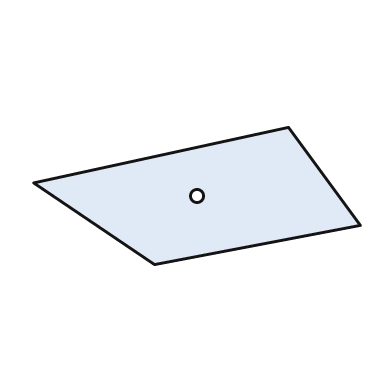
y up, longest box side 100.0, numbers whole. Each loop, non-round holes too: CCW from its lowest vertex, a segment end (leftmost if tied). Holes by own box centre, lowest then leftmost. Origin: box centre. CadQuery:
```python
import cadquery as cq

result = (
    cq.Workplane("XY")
    .moveTo(-13.0, -21.0)
    .lineTo(50.0, -9.0)
    .lineTo(28.0, 21.0)
    .lineTo(-50.0, 4.0)
    .close()
    .moveTo(0.0, 0.0)
    .circle(2.0)
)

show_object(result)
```